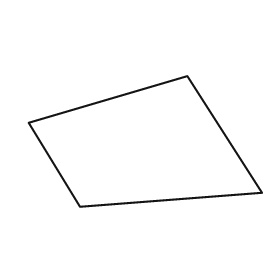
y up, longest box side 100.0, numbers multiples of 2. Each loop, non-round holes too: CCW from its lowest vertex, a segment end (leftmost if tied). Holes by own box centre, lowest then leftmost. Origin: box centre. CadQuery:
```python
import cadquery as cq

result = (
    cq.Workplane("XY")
    .moveTo(-28.0, -28.0)
    .lineTo(50.0, -22.0)
    .lineTo(18.0, 28.0)
    .lineTo(-50.0, 8.0)
    .close()
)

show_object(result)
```